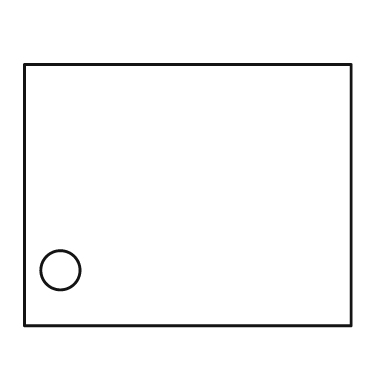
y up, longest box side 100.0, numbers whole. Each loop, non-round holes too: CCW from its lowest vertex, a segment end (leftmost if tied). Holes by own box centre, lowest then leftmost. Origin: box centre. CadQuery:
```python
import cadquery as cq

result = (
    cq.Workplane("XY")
    .moveTo(-50.0, -40.0)
    .lineTo(50.0, -40.0)
    .lineTo(50.0, 40.0)
    .lineTo(-50.0, 40.0)
    .close()
    .moveTo(-39.0, -23.0)
    .circle(6.0)
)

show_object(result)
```